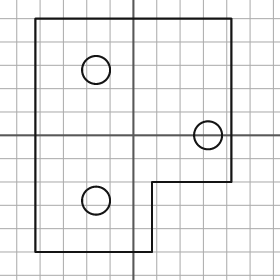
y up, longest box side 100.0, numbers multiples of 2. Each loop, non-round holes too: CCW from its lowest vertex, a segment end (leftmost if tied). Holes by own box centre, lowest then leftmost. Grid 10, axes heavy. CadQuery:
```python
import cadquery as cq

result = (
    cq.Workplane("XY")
    .moveTo(-42.0, -50.0)
    .lineTo(8.0, -50.0)
    .lineTo(8.0, -20.0)
    .lineTo(42.0, -20.0)
    .lineTo(42.0, 50.0)
    .lineTo(-42.0, 50.0)
    .close()
    .moveTo(-16.0, -28.0)
    .circle(6.0)
    .moveTo(32.0, 0.0)
    .circle(6.0)
    .moveTo(-16.0, 28.0)
    .circle(6.0)
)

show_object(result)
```